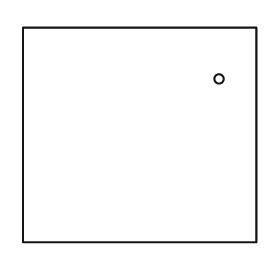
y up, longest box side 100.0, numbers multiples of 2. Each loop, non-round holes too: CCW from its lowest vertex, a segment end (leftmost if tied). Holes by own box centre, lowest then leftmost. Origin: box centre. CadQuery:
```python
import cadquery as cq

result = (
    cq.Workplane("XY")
    .moveTo(-50.0, -46.0)
    .lineTo(50.0, -46.0)
    .lineTo(50.0, 46.0)
    .lineTo(-50.0, 46.0)
    .close()
    .moveTo(34.0, 24.0)
    .circle(2.0)
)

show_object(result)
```